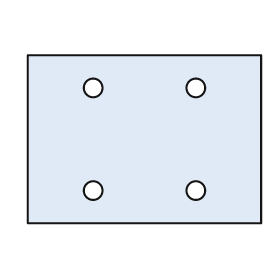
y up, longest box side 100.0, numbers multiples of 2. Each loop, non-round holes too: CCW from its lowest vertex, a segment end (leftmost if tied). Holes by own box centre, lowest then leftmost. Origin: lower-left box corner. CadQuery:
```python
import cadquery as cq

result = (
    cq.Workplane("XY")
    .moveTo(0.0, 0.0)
    .lineTo(100.0, 0.0)
    .lineTo(100.0, 72.0)
    .lineTo(0.0, 72.0)
    .close()
    .moveTo(28.0, 14.0)
    .circle(4.0)
    .moveTo(72.0, 14.0)
    .circle(4.0)
    .moveTo(28.0, 58.0)
    .circle(4.0)
    .moveTo(72.0, 58.0)
    .circle(4.0)
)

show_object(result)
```